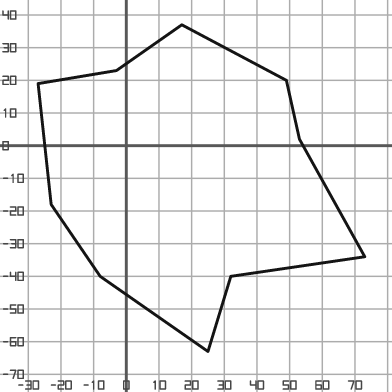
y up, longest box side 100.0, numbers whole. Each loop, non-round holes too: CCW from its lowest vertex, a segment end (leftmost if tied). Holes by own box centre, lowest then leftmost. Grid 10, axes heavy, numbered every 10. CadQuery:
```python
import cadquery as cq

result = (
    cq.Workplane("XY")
    .moveTo(25.0, -63.0)
    .lineTo(32.0, -40.0)
    .lineTo(73.0, -34.0)
    .lineTo(53.0, 2.0)
    .lineTo(49.0, 20.0)
    .lineTo(17.0, 37.0)
    .lineTo(-3.0, 23.0)
    .lineTo(-27.0, 19.0)
    .lineTo(-23.0, -18.0)
    .lineTo(-8.0, -40.0)
    .close()
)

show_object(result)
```